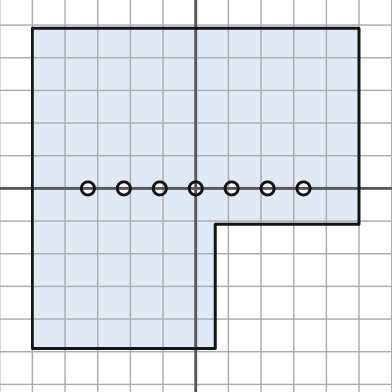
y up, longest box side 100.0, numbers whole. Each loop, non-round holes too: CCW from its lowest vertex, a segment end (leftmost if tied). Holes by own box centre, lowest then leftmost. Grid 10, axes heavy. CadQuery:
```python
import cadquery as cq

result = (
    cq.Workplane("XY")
    .moveTo(-50.0, -49.0)
    .lineTo(6.0, -49.0)
    .lineTo(6.0, -11.0)
    .lineTo(50.0, -11.0)
    .lineTo(50.0, 49.0)
    .lineTo(-50.0, 49.0)
    .close()
    .moveTo(-33.0, 0.0)
    .circle(2.0)
    .moveTo(-22.0, 0.0)
    .circle(2.0)
    .moveTo(-11.0, 0.0)
    .circle(2.0)
    .moveTo(0.0, 0.0)
    .circle(2.0)
    .moveTo(11.0, 0.0)
    .circle(2.0)
    .moveTo(22.0, 0.0)
    .circle(2.0)
    .moveTo(33.0, 0.0)
    .circle(2.0)
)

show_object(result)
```